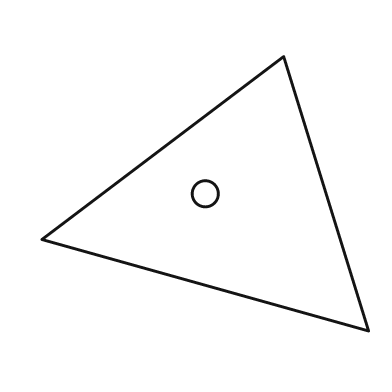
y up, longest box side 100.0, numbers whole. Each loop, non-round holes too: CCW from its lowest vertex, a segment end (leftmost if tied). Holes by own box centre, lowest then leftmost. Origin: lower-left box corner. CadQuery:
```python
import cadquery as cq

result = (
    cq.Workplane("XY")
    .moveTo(100.0, 0.0)
    .lineTo(74.0, 84.0)
    .lineTo(0.0, 28.0)
    .close()
    .moveTo(50.0, 42.0)
    .circle(4.0)
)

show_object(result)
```